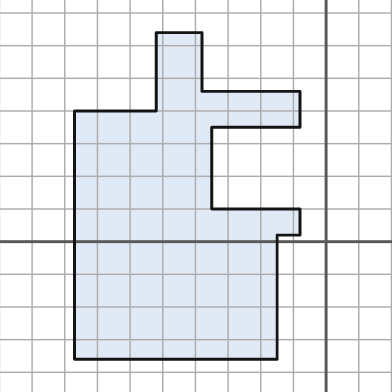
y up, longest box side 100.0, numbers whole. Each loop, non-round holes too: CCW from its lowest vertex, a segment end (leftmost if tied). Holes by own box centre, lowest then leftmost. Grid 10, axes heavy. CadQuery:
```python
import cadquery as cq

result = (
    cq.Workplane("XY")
    .moveTo(-77.0, -36.0)
    .lineTo(-15.0, -36.0)
    .lineTo(-15.0, 2.0)
    .lineTo(-8.0, 2.0)
    .lineTo(-8.0, 10.0)
    .lineTo(-35.0, 10.0)
    .lineTo(-35.0, 35.0)
    .lineTo(-8.0, 35.0)
    .lineTo(-8.0, 46.0)
    .lineTo(-38.0, 46.0)
    .lineTo(-38.0, 64.0)
    .lineTo(-52.0, 64.0)
    .lineTo(-52.0, 40.0)
    .lineTo(-77.0, 40.0)
    .close()
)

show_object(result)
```